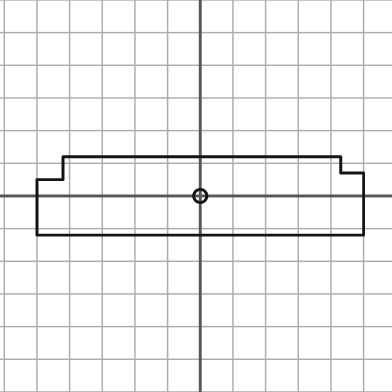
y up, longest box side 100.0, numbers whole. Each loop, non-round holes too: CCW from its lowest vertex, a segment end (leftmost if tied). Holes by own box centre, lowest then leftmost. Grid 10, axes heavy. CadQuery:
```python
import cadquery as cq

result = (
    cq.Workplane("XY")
    .moveTo(-50.0, -12.0)
    .lineTo(50.0, -12.0)
    .lineTo(50.0, 7.0)
    .lineTo(43.0, 7.0)
    .lineTo(43.0, 12.0)
    .lineTo(-42.0, 12.0)
    .lineTo(-42.0, 5.0)
    .lineTo(-50.0, 5.0)
    .close()
    .moveTo(0.0, 0.0)
    .circle(2.0)
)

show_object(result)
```